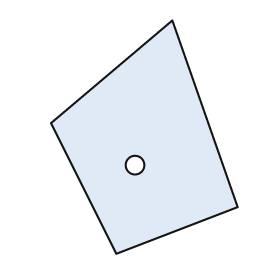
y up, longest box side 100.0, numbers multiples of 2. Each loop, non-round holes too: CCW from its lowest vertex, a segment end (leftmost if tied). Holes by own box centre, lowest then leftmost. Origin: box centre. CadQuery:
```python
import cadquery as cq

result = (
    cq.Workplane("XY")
    .moveTo(-12.0, -50.0)
    .lineTo(40.0, -30.0)
    .lineTo(12.0, 50.0)
    .lineTo(-40.0, 6.0)
    .close()
    .moveTo(-4.0, -12.0)
    .circle(4.0)
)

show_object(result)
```